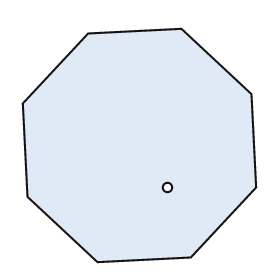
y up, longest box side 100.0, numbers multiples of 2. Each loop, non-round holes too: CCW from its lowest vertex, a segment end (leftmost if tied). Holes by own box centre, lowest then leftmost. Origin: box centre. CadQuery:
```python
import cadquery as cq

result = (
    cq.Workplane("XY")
    .moveTo(-18.0, -50.0)
    .lineTo(22.0, -48.0)
    .lineTo(50.0, -18.0)
    .lineTo(48.0, 22.0)
    .lineTo(18.0, 50.0)
    .lineTo(-22.0, 48.0)
    .lineTo(-50.0, 18.0)
    .lineTo(-48.0, -22.0)
    .close()
    .moveTo(12.0, -18.0)
    .circle(2.0)
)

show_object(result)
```